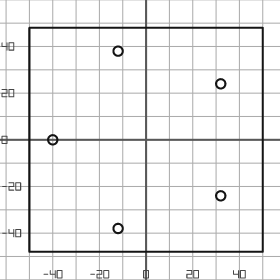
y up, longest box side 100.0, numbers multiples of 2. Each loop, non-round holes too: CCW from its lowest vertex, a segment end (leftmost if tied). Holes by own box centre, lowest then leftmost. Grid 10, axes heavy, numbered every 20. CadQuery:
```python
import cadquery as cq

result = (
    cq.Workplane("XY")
    .moveTo(-50.0, -48.0)
    .lineTo(50.0, -48.0)
    .lineTo(50.0, 48.0)
    .lineTo(-50.0, 48.0)
    .close()
    .moveTo(-12.0, -38.0)
    .circle(2.0)
    .moveTo(32.0, -24.0)
    .circle(2.0)
    .moveTo(-40.0, 0.0)
    .circle(2.0)
    .moveTo(32.0, 24.0)
    .circle(2.0)
    .moveTo(-12.0, 38.0)
    .circle(2.0)
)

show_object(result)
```